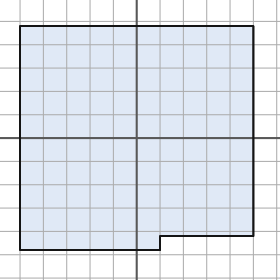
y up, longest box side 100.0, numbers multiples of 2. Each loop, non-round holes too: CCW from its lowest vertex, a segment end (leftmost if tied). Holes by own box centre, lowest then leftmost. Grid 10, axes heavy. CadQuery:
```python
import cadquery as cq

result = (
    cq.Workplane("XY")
    .moveTo(-50.0, -48.0)
    .lineTo(10.0, -48.0)
    .lineTo(10.0, -42.0)
    .lineTo(50.0, -42.0)
    .lineTo(50.0, 48.0)
    .lineTo(-50.0, 48.0)
    .close()
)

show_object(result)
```